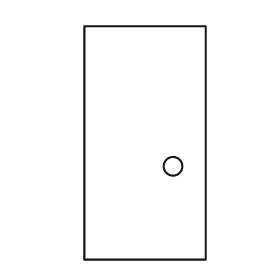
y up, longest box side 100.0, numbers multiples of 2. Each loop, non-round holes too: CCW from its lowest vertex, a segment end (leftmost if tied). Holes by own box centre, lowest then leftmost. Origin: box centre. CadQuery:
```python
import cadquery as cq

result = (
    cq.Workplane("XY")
    .moveTo(-26.0, -50.0)
    .lineTo(26.0, -50.0)
    .lineTo(26.0, 50.0)
    .lineTo(-26.0, 50.0)
    .close()
    .moveTo(12.0, -10.0)
    .circle(4.0)
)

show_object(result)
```